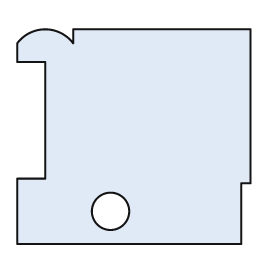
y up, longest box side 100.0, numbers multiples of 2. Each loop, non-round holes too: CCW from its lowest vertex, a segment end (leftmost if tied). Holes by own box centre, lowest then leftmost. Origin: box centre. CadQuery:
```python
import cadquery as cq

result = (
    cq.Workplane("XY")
    .moveTo(-50.0, -46.0)
    .lineTo(46.0, -46.0)
    .lineTo(46.0, -20.0)
    .lineTo(50.0, -20.0)
    .lineTo(50.0, 46.0)
    .lineTo(-26.0, 46.0)
    .lineTo(-26.0, 40.0)
    .threePointArc((-38.0, 46.0), (-50.0, 40.0))
    .lineTo(-50.0, 32.0)
    .lineTo(-38.0, 32.0)
    .lineTo(-38.0, -18.0)
    .lineTo(-50.0, -18.0)
    .close()
    .moveTo(-10.0, -32.0)
    .circle(8.0)
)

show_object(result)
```